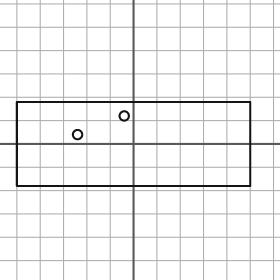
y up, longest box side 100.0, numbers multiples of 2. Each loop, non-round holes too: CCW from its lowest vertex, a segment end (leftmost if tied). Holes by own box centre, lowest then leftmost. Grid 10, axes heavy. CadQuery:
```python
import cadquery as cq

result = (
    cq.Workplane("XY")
    .moveTo(-50.0, -18.0)
    .lineTo(50.0, -18.0)
    .lineTo(50.0, 18.0)
    .lineTo(-50.0, 18.0)
    .close()
    .moveTo(-24.0, 4.0)
    .circle(2.0)
    .moveTo(-4.0, 12.0)
    .circle(2.0)
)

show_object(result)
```